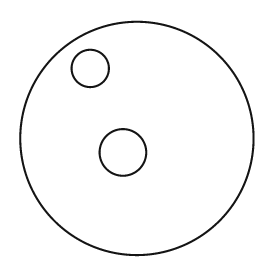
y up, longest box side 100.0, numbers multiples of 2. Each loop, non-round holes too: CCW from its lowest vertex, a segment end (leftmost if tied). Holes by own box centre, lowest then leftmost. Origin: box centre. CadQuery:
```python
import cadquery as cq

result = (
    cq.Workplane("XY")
    .moveTo(0.0, 0.0)
    .circle(50.0)
    .moveTo(-6.0, -6.0)
    .circle(10.0)
    .moveTo(-20.0, 30.0)
    .circle(8.0)
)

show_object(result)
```